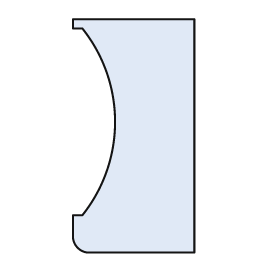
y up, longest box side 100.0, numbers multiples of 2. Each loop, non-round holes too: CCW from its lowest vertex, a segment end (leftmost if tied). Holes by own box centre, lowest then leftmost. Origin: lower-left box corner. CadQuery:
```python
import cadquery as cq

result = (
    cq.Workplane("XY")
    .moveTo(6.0, 0.0)
    .lineTo(52.0, 0.0)
    .lineTo(52.0, 100.0)
    .lineTo(0.0, 100.0)
    .lineTo(0.0, 96.0)
    .lineTo(4.0, 96.0)
    .threePointArc((18.0, 56.0), (4.0, 16.0))
    .lineTo(0.0, 16.0)
    .lineTo(0.0, 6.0)
    .threePointArc((2.0, 2.0), (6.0, 0.0))
    .close()
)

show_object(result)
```